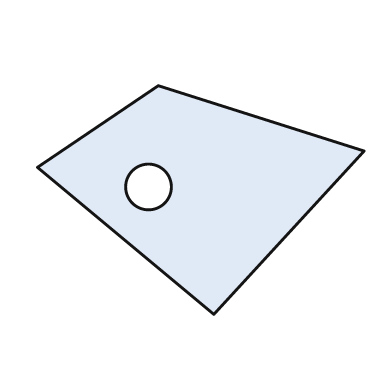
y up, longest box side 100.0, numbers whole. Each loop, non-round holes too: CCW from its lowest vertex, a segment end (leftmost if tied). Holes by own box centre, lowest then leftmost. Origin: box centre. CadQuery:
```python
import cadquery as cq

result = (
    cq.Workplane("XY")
    .moveTo(4.0, -35.0)
    .lineTo(50.0, 15.0)
    .lineTo(-13.0, 35.0)
    .lineTo(-50.0, 10.0)
    .close()
    .moveTo(-16.0, 4.0)
    .circle(7.0)
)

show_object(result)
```